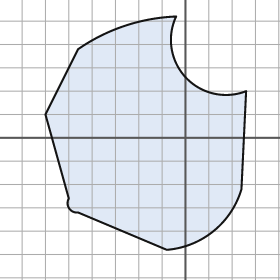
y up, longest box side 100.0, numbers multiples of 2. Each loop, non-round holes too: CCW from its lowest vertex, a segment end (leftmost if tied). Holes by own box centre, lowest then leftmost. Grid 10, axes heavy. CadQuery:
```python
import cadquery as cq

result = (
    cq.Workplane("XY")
    .moveTo(-8.0, -48.0)
    .threePointArc((12.0, -40.0), (24.0, -22.0))
    .lineTo(26.0, 20.0)
    .threePointArc((0.0, 26.0), (-4.0, 52.0))
    .threePointArc((-26.0, 48.0), (-46.0, 38.0))
    .lineTo(-60.0, 10.0)
    .lineTo(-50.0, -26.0)
    .threePointArc((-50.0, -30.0), (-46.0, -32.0))
    .close()
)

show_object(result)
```